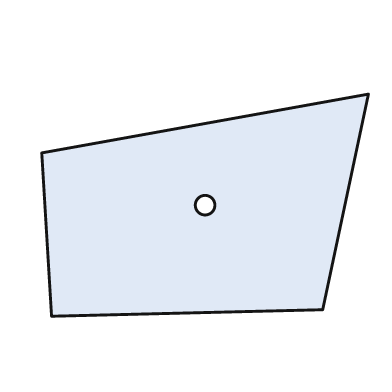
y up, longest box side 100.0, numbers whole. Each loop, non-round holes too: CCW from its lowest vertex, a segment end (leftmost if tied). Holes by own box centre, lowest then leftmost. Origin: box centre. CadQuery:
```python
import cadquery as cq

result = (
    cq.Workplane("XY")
    .moveTo(-47.0, -34.0)
    .lineTo(36.0, -32.0)
    .lineTo(50.0, 34.0)
    .lineTo(-50.0, 16.0)
    .close()
    .moveTo(0.0, 0.0)
    .circle(3.0)
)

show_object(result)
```